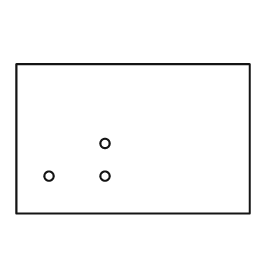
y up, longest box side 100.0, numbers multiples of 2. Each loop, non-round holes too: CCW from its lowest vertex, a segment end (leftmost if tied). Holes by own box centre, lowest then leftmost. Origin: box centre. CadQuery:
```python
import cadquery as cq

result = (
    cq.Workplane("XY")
    .moveTo(-50.0, -32.0)
    .lineTo(50.0, -32.0)
    .lineTo(50.0, 32.0)
    .lineTo(-50.0, 32.0)
    .close()
    .moveTo(-36.0, -16.0)
    .circle(2.0)
    .moveTo(-12.0, -16.0)
    .circle(2.0)
    .moveTo(-12.0, -2.0)
    .circle(2.0)
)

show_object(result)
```